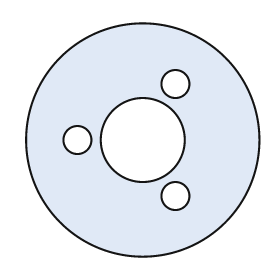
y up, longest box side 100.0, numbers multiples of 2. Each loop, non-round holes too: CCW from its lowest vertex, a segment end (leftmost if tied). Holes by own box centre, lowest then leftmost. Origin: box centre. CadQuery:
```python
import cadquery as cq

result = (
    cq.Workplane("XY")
    .moveTo(0.0, 0.0)
    .circle(50.0)
    .moveTo(14.0, -24.0)
    .circle(6.0)
    .moveTo(-28.0, 0.0)
    .circle(6.0)
    .moveTo(0.0, 0.0)
    .circle(18.0)
    .moveTo(14.0, 24.0)
    .circle(6.0)
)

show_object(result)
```